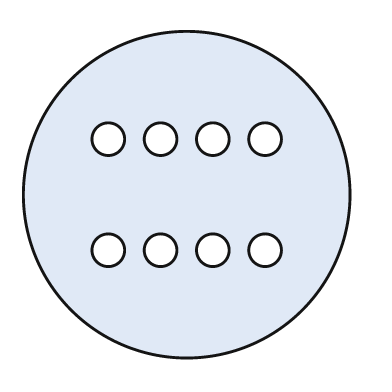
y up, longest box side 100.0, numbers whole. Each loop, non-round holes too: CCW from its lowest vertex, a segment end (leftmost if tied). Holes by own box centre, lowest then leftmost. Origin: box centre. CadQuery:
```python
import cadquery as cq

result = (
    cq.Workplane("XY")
    .moveTo(0.0, 0.0)
    .circle(50.0)
    .moveTo(-24.0, -17.0)
    .circle(5.0)
    .moveTo(-8.0, -17.0)
    .circle(5.0)
    .moveTo(8.0, -17.0)
    .circle(5.0)
    .moveTo(24.0, -17.0)
    .circle(5.0)
    .moveTo(-24.0, 17.0)
    .circle(5.0)
    .moveTo(-8.0, 17.0)
    .circle(5.0)
    .moveTo(8.0, 17.0)
    .circle(5.0)
    .moveTo(24.0, 17.0)
    .circle(5.0)
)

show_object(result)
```